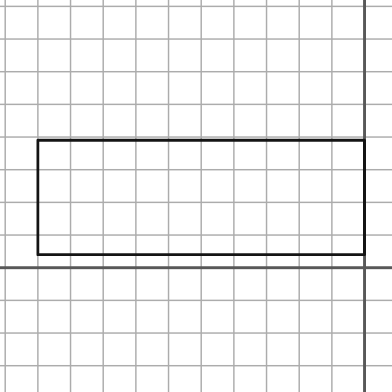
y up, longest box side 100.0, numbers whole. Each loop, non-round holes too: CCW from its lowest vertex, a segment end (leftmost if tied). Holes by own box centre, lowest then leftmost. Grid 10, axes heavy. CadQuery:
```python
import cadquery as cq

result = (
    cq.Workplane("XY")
    .moveTo(-100.0, 4.0)
    .lineTo(0.0, 4.0)
    .lineTo(0.0, 39.0)
    .lineTo(-100.0, 39.0)
    .close()
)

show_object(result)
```